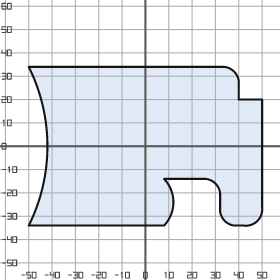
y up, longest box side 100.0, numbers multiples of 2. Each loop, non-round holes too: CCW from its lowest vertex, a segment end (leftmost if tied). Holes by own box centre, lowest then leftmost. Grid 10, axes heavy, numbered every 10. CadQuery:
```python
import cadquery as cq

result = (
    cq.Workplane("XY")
    .moveTo(-50.0, -34.0)
    .lineTo(8.0, -34.0)
    .threePointArc((12.0, -24.0), (8.0, -14.0))
    .lineTo(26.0, -14.0)
    .threePointArc((30.0, -16.0), (32.0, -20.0))
    .lineTo(32.0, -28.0)
    .threePointArc((34.0, -32.0), (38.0, -34.0))
    .lineTo(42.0, -34.0)
    .threePointArc((48.0, -32.0), (50.0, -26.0))
    .lineTo(50.0, 20.0)
    .lineTo(40.0, 20.0)
    .lineTo(40.0, 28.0)
    .threePointArc((38.0, 32.0), (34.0, 34.0))
    .lineTo(-50.0, 34.0)
    .threePointArc((-42.0, 0.0), (-50.0, -34.0))
    .close()
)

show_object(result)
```